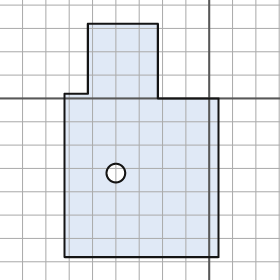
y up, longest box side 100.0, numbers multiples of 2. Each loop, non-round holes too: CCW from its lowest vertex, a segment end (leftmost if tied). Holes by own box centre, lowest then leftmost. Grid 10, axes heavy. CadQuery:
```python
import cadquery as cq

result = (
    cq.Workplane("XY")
    .moveTo(-62.0, -68.0)
    .lineTo(4.0, -68.0)
    .lineTo(4.0, 0.0)
    .lineTo(-22.0, 0.0)
    .lineTo(-22.0, 32.0)
    .lineTo(-52.0, 32.0)
    .lineTo(-52.0, 2.0)
    .lineTo(-62.0, 2.0)
    .close()
    .moveTo(-40.0, -32.0)
    .circle(4.0)
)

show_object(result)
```